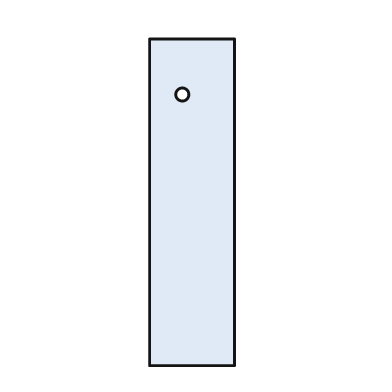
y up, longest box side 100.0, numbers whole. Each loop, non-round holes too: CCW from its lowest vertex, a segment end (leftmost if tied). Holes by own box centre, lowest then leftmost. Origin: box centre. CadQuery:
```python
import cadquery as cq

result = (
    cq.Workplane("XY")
    .moveTo(-13.0, -50.0)
    .lineTo(13.0, -50.0)
    .lineTo(13.0, 50.0)
    .lineTo(-13.0, 50.0)
    .close()
    .moveTo(-3.0, 33.0)
    .circle(2.0)
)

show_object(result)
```